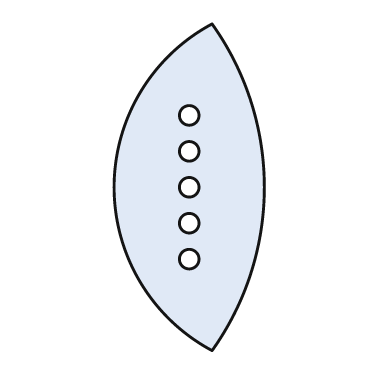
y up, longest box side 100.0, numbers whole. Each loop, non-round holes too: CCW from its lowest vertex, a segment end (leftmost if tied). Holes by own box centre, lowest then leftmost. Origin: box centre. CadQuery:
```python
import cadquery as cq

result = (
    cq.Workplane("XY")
    .moveTo(7.0, -50.0)
    .threePointArc((23.0, 0.0), (7.0, 50.0))
    .threePointArc((-23.0, 0.0), (7.0, -50.0))
    .close()
    .moveTo(0.0, -22.0)
    .circle(3.0)
    .moveTo(0.0, -11.0)
    .circle(3.0)
    .moveTo(0.0, 0.0)
    .circle(3.0)
    .moveTo(0.0, 11.0)
    .circle(3.0)
    .moveTo(0.0, 22.0)
    .circle(3.0)
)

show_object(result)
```